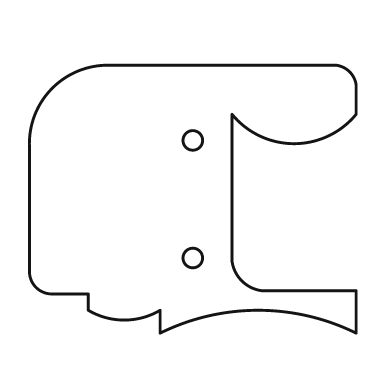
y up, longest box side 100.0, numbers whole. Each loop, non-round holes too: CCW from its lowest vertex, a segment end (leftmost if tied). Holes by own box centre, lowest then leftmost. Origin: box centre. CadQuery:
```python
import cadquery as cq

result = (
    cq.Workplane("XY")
    .moveTo(-10.0, -41.0)
    .threePointArc((20.0, -34.0), (50.0, -41.0))
    .lineTo(50.0, -28.0)
    .lineTo(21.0, -28.0)
    .threePointArc((15.0, -25.0), (12.0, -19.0))
    .lineTo(12.0, 26.0)
    .threePointArc((31.0, 17.0), (50.0, 26.0))
    .lineTo(50.0, 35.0)
    .threePointArc((48.0, 39.0), (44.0, 41.0))
    .lineTo(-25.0, 41.0)
    .threePointArc((-43.0, 34.0), (-50.0, 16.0))
    .lineTo(-50.0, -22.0)
    .threePointArc((-48.0, -27.0), (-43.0, -29.0))
    .lineTo(-32.0, -29.0)
    .lineTo(-32.0, -34.0)
    .threePointArc((-21.0, -37.0), (-10.0, -34.0))
    .close()
    .moveTo(0.0, -18.0)
    .circle(3.0)
    .moveTo(0.0, 18.0)
    .circle(3.0)
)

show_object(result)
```